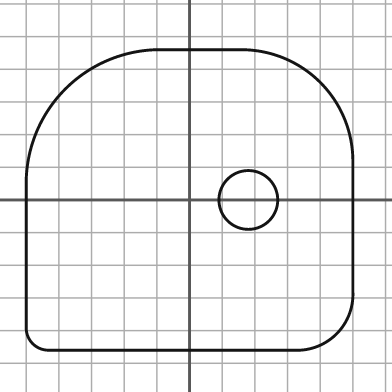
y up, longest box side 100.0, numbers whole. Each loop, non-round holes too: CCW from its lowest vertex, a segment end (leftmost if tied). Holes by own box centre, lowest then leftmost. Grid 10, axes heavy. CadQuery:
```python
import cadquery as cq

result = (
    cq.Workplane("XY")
    .moveTo(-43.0, -46.0)
    .lineTo(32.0, -46.0)
    .threePointArc((45.0, -41.0), (50.0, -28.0))
    .lineTo(50.0, 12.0)
    .threePointArc((40.0, 36.0), (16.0, 46.0))
    .lineTo(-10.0, 46.0)
    .threePointArc((-38.0, 34.0), (-50.0, 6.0))
    .lineTo(-50.0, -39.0)
    .threePointArc((-48.0, -44.0), (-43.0, -46.0))
    .close()
    .moveTo(18.0, 0.0)
    .circle(9.0)
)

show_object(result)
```